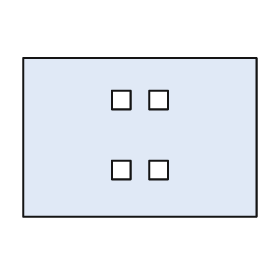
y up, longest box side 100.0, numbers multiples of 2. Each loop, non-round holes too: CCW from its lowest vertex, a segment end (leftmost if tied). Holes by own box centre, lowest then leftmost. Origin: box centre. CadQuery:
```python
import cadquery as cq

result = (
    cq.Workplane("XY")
    .moveTo(-50.0, -34.0)
    .lineTo(50.0, -34.0)
    .lineTo(50.0, 34.0)
    .lineTo(-50.0, 34.0)
    .close()
    .moveTo(-12.0, -18.0)
    .lineTo(-4.0, -18.0)
    .lineTo(-4.0, -10.0)
    .lineTo(-12.0, -10.0)
    .close()
    .moveTo(4.0, -18.0)
    .lineTo(12.0, -18.0)
    .lineTo(12.0, -10.0)
    .lineTo(4.0, -10.0)
    .close()
    .moveTo(-12.0, 12.0)
    .lineTo(-4.0, 12.0)
    .lineTo(-4.0, 20.0)
    .lineTo(-12.0, 20.0)
    .close()
    .moveTo(4.0, 12.0)
    .lineTo(12.0, 12.0)
    .lineTo(12.0, 20.0)
    .lineTo(4.0, 20.0)
    .close()
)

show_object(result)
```